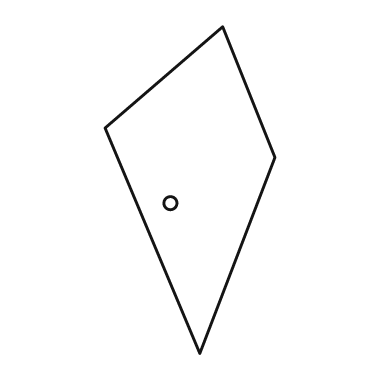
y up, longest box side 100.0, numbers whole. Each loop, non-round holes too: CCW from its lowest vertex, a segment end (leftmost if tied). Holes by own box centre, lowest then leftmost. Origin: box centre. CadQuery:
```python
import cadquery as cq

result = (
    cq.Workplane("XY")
    .moveTo(3.0, -50.0)
    .lineTo(26.0, 10.0)
    .lineTo(10.0, 50.0)
    .lineTo(-26.0, 19.0)
    .close()
    .moveTo(-6.0, -4.0)
    .circle(2.0)
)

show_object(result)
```